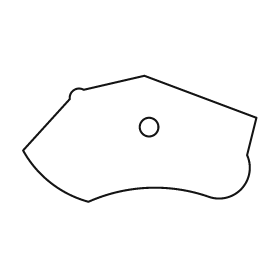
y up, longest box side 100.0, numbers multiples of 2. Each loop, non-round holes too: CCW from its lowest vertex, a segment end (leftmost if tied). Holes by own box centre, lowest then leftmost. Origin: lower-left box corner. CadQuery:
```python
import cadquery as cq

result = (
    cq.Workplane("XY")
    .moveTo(28.0, 0.0)
    .threePointArc((54.0, 6.0), (80.0, 2.0))
    .threePointArc((94.0, 6.0), (96.0, 20.0))
    .lineTo(100.0, 36.0)
    .lineTo(52.0, 54.0)
    .lineTo(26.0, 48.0)
    .threePointArc((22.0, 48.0), (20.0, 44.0))
    .lineTo(0.0, 22.0)
    .threePointArc((12.0, 8.0), (28.0, 0.0))
    .close()
    .moveTo(54.0, 32.0)
    .circle(4.0)
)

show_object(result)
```